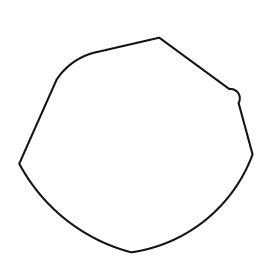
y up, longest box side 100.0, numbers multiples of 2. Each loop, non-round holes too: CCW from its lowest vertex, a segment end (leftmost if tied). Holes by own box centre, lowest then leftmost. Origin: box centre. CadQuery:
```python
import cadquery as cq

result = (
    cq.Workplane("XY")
    .moveTo(-2.0, -46.0)
    .threePointArc((30.0, -32.0), (50.0, -4.0))
    .lineTo(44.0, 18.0)
    .threePointArc((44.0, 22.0), (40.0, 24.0))
    .lineTo(10.0, 46.0)
    .lineTo(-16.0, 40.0)
    .threePointArc((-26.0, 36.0), (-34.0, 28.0))
    .lineTo(-50.0, -8.0)
    .threePointArc((-30.0, -32.0), (-2.0, -46.0))
    .close()
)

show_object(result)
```